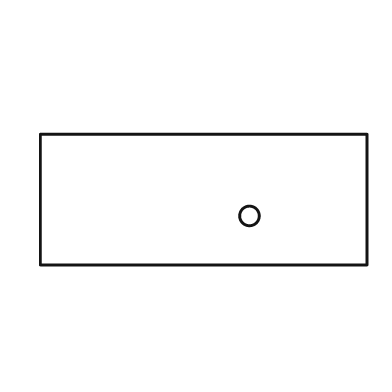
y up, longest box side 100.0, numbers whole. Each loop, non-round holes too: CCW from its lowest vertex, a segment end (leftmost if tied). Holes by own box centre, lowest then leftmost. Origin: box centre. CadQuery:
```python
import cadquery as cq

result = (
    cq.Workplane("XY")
    .moveTo(-50.0, -20.0)
    .lineTo(50.0, -20.0)
    .lineTo(50.0, 20.0)
    .lineTo(-50.0, 20.0)
    .close()
    .moveTo(14.0, -5.0)
    .circle(3.0)
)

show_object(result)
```